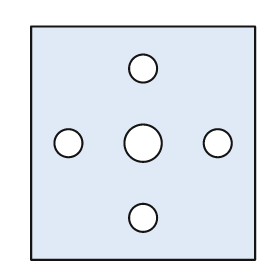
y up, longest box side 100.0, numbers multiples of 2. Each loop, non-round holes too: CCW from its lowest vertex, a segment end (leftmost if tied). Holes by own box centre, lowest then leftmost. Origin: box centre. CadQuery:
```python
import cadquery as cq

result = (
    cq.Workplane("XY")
    .moveTo(-48.0, -50.0)
    .lineTo(48.0, -50.0)
    .lineTo(48.0, 50.0)
    .lineTo(-48.0, 50.0)
    .close()
    .moveTo(0.0, -32.0)
    .circle(6.0)
    .moveTo(-32.0, 0.0)
    .circle(6.0)
    .moveTo(0.0, 0.0)
    .circle(8.0)
    .moveTo(32.0, 0.0)
    .circle(6.0)
    .moveTo(0.0, 32.0)
    .circle(6.0)
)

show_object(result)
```